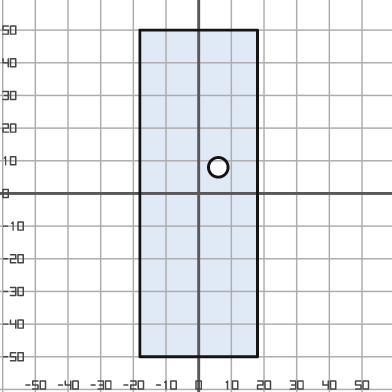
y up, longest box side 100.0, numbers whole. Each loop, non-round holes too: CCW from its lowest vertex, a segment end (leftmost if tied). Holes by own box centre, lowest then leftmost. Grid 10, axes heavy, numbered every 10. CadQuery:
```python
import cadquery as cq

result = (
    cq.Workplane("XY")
    .moveTo(-18.0, -50.0)
    .lineTo(18.0, -50.0)
    .lineTo(18.0, 50.0)
    .lineTo(-18.0, 50.0)
    .close()
    .moveTo(6.0, 8.0)
    .circle(3.0)
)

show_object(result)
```